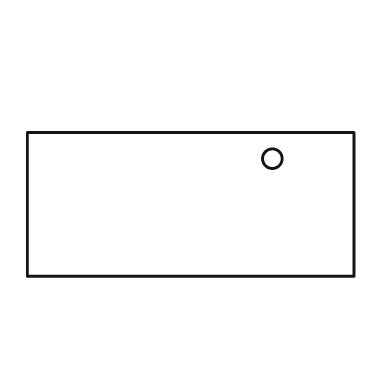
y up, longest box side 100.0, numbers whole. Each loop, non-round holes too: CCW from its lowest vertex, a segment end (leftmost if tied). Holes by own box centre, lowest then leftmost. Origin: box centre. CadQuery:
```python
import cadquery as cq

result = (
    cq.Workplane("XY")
    .moveTo(-50.0, -22.0)
    .lineTo(50.0, -22.0)
    .lineTo(50.0, 22.0)
    .lineTo(-50.0, 22.0)
    .close()
    .moveTo(25.0, 14.0)
    .circle(3.0)
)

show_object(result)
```